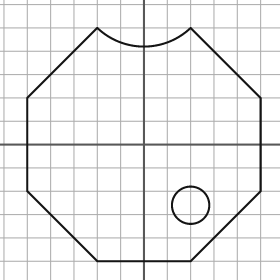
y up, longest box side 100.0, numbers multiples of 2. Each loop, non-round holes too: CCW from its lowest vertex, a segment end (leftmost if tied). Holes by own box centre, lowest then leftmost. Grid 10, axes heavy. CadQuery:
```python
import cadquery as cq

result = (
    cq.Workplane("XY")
    .moveTo(-20.0, -50.0)
    .lineTo(20.0, -50.0)
    .lineTo(50.0, -20.0)
    .lineTo(50.0, 20.0)
    .lineTo(20.0, 50.0)
    .threePointArc((0.0, 42.0), (-20.0, 50.0))
    .lineTo(-50.0, 20.0)
    .lineTo(-50.0, -20.0)
    .close()
    .moveTo(20.0, -26.0)
    .circle(8.0)
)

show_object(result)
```